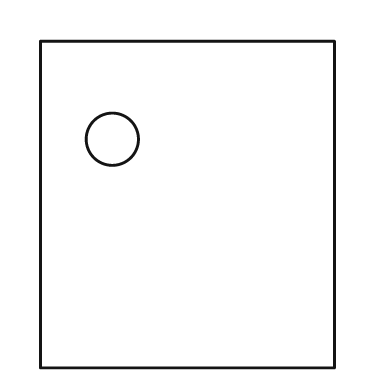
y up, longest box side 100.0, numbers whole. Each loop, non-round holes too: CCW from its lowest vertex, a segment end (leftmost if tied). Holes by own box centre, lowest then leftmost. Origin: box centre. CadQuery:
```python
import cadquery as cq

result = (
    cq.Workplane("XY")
    .moveTo(-45.0, -50.0)
    .lineTo(45.0, -50.0)
    .lineTo(45.0, 50.0)
    .lineTo(-45.0, 50.0)
    .close()
    .moveTo(-23.0, 20.0)
    .circle(8.0)
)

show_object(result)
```